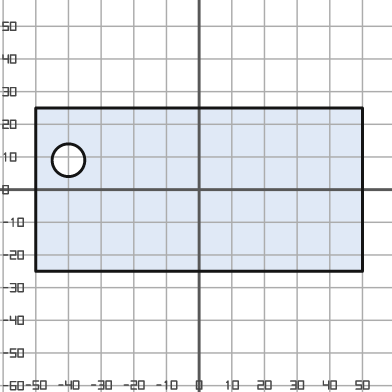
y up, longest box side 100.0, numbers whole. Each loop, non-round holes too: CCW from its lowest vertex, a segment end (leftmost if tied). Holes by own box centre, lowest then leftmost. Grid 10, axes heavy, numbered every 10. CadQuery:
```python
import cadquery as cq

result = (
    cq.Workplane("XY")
    .moveTo(-50.0, -25.0)
    .lineTo(50.0, -25.0)
    .lineTo(50.0, 25.0)
    .lineTo(-50.0, 25.0)
    .close()
    .moveTo(-40.0, 9.0)
    .circle(5.0)
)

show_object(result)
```